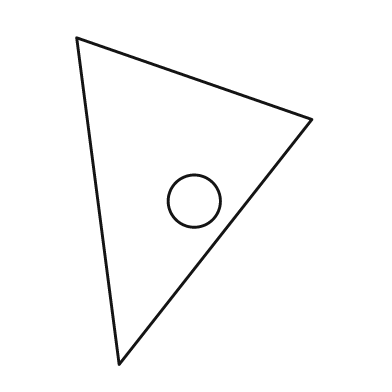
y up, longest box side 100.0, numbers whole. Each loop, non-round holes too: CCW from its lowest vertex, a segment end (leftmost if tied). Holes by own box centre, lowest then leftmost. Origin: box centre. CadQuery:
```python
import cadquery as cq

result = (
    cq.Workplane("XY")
    .moveTo(-23.0, -50.0)
    .lineTo(36.0, 25.0)
    .lineTo(-36.0, 50.0)
    .close()
    .moveTo(0.0, 0.0)
    .circle(8.0)
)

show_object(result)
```